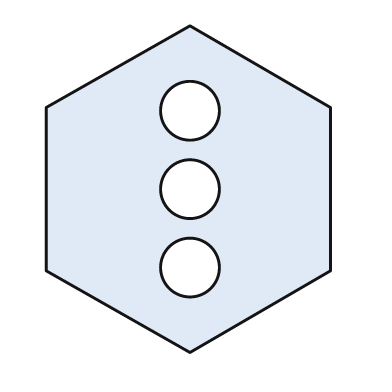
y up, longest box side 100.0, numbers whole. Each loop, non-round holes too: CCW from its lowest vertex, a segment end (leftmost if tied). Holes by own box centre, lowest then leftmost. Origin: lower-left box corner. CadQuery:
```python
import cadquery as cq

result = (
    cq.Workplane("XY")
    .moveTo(44.0, 0.0)
    .lineTo(87.0, 25.0)
    .lineTo(87.0, 75.0)
    .lineTo(44.0, 100.0)
    .lineTo(0.0, 75.0)
    .lineTo(0.0, 25.0)
    .close()
    .moveTo(44.0, 26.0)
    .circle(9.0)
    .moveTo(44.0, 50.0)
    .circle(9.0)
    .moveTo(44.0, 74.0)
    .circle(9.0)
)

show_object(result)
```